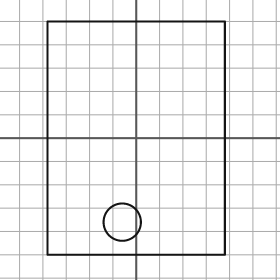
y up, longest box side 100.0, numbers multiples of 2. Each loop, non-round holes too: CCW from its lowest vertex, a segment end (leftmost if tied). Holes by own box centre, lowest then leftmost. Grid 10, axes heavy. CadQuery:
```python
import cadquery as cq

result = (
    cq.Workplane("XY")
    .moveTo(-38.0, -50.0)
    .lineTo(38.0, -50.0)
    .lineTo(38.0, 50.0)
    .lineTo(-38.0, 50.0)
    .close()
    .moveTo(-6.0, -36.0)
    .circle(8.0)
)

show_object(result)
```